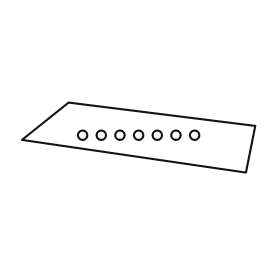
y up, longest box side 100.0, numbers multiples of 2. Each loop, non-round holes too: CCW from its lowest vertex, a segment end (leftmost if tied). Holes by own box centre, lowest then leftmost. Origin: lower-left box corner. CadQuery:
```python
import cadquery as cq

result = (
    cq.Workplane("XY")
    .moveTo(96.0, 0.0)
    .lineTo(100.0, 20.0)
    .lineTo(20.0, 30.0)
    .lineTo(0.0, 14.0)
    .close()
    .moveTo(26.0, 16.0)
    .circle(2.0)
    .moveTo(34.0, 16.0)
    .circle(2.0)
    .moveTo(42.0, 16.0)
    .circle(2.0)
    .moveTo(50.0, 16.0)
    .circle(2.0)
    .moveTo(58.0, 16.0)
    .circle(2.0)
    .moveTo(66.0, 16.0)
    .circle(2.0)
    .moveTo(74.0, 16.0)
    .circle(2.0)
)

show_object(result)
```